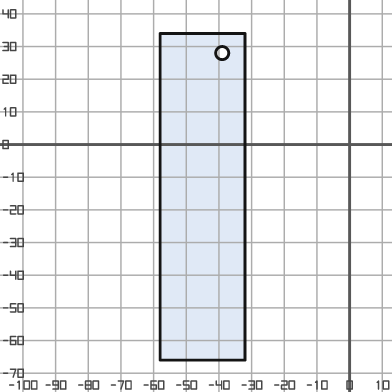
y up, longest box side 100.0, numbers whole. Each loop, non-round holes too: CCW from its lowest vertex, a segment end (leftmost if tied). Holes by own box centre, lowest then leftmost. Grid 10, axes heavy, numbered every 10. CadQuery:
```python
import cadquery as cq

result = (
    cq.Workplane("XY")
    .moveTo(-58.0, -66.0)
    .lineTo(-32.0, -66.0)
    .lineTo(-32.0, 34.0)
    .lineTo(-58.0, 34.0)
    .close()
    .moveTo(-39.0, 28.0)
    .circle(2.0)
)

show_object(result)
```